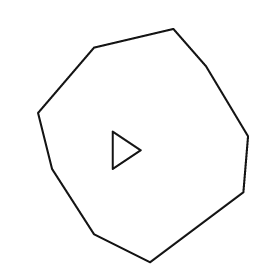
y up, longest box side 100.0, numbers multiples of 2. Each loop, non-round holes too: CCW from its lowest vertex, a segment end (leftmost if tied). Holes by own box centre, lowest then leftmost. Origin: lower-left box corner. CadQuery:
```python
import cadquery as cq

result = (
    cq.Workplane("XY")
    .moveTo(48.0, 0.0)
    .lineTo(88.0, 30.0)
    .lineTo(90.0, 54.0)
    .lineTo(72.0, 84.0)
    .lineTo(58.0, 100.0)
    .lineTo(24.0, 92.0)
    .lineTo(0.0, 64.0)
    .lineTo(6.0, 40.0)
    .lineTo(24.0, 12.0)
    .close()
    .moveTo(32.0, 40.0)
    .lineTo(44.0, 48.0)
    .lineTo(32.0, 56.0)
    .close()
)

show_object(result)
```